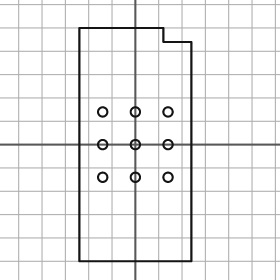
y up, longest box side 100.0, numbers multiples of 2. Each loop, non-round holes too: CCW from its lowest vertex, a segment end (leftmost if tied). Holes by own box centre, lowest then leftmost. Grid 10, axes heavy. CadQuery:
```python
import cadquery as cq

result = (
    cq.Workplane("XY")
    .moveTo(-24.0, -50.0)
    .lineTo(24.0, -50.0)
    .lineTo(24.0, 44.0)
    .lineTo(12.0, 44.0)
    .lineTo(12.0, 50.0)
    .lineTo(-24.0, 50.0)
    .close()
    .moveTo(-14.0, -14.0)
    .circle(2.0)
    .moveTo(0.0, -14.0)
    .circle(2.0)
    .moveTo(14.0, -14.0)
    .circle(2.0)
    .moveTo(-14.0, 0.0)
    .circle(2.0)
    .moveTo(0.0, 0.0)
    .circle(2.0)
    .moveTo(14.0, 0.0)
    .circle(2.0)
    .moveTo(-14.0, 14.0)
    .circle(2.0)
    .moveTo(0.0, 14.0)
    .circle(2.0)
    .moveTo(14.0, 14.0)
    .circle(2.0)
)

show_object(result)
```